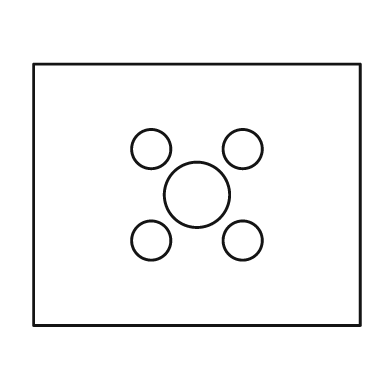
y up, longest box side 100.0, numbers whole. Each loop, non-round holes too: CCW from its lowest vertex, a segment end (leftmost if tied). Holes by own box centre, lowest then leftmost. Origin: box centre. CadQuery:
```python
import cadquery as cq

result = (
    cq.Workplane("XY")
    .moveTo(-50.0, -40.0)
    .lineTo(50.0, -40.0)
    .lineTo(50.0, 40.0)
    .lineTo(-50.0, 40.0)
    .close()
    .moveTo(-14.0, -14.0)
    .circle(6.0)
    .moveTo(14.0, -14.0)
    .circle(6.0)
    .moveTo(0.0, 0.0)
    .circle(10.0)
    .moveTo(-14.0, 14.0)
    .circle(6.0)
    .moveTo(14.0, 14.0)
    .circle(6.0)
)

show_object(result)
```